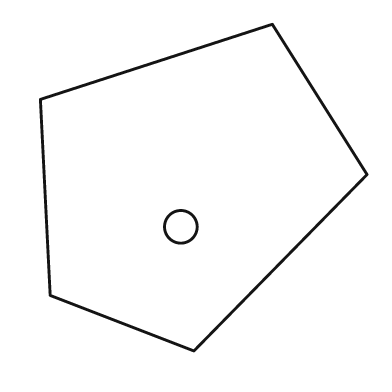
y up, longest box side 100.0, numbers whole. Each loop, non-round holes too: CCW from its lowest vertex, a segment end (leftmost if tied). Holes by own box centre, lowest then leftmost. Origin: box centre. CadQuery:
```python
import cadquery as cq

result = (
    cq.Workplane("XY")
    .moveTo(-3.0, -50.0)
    .lineTo(50.0, 4.0)
    .lineTo(21.0, 50.0)
    .lineTo(-50.0, 27.0)
    .lineTo(-47.0, -33.0)
    .close()
    .moveTo(-7.0, -12.0)
    .circle(5.0)
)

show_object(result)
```